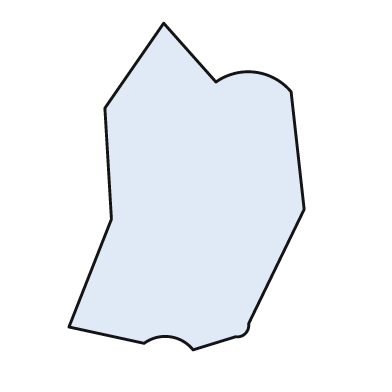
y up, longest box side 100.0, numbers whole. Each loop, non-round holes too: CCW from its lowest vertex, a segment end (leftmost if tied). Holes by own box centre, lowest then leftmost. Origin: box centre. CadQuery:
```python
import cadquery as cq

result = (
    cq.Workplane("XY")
    .moveTo(2.0, -50.0)
    .lineTo(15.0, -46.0)
    .threePointArc((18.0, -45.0), (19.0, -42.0))
    .lineTo(36.0, -7.0)
    .lineTo(32.0, 29.0)
    .threePointArc((21.0, 35.0), (9.0, 32.0))
    .lineTo(-7.0, 50.0)
    .lineTo(-25.0, 24.0)
    .lineTo(-23.0, -10.0)
    .lineTo(-36.0, -43.0)
    .lineTo(-13.0, -48.0)
    .threePointArc((-5.0, -46.0), (2.0, -50.0))
    .close()
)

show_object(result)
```